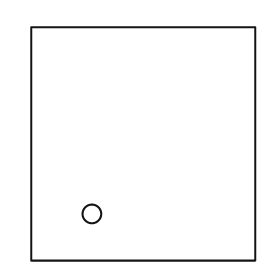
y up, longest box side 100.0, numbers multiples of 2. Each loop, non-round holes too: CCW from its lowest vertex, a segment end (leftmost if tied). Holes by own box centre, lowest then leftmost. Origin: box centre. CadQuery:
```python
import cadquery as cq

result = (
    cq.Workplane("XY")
    .moveTo(-48.0, -50.0)
    .lineTo(48.0, -50.0)
    .lineTo(48.0, 50.0)
    .lineTo(-48.0, 50.0)
    .close()
    .moveTo(-22.0, -30.0)
    .circle(4.0)
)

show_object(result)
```